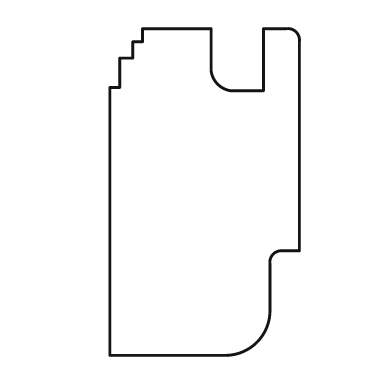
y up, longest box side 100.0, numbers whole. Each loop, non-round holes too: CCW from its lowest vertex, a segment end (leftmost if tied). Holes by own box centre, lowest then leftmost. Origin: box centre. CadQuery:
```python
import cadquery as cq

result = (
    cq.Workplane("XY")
    .moveTo(-29.0, -50.0)
    .lineTo(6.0, -50.0)
    .threePointArc((16.0, -46.0), (20.0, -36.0))
    .lineTo(20.0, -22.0)
    .threePointArc((21.0, -19.0), (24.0, -18.0))
    .lineTo(29.0, -18.0)
    .lineTo(29.0, 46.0)
    .threePointArc((28.0, 49.0), (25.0, 50.0))
    .lineTo(18.0, 50.0)
    .lineTo(18.0, 31.0)
    .lineTo(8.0, 31.0)
    .threePointArc((4.0, 33.0), (2.0, 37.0))
    .lineTo(2.0, 50.0)
    .lineTo(-19.0, 50.0)
    .lineTo(-19.0, 46.0)
    .lineTo(-22.0, 46.0)
    .lineTo(-22.0, 41.0)
    .lineTo(-26.0, 41.0)
    .lineTo(-26.0, 32.0)
    .lineTo(-29.0, 32.0)
    .close()
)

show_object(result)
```